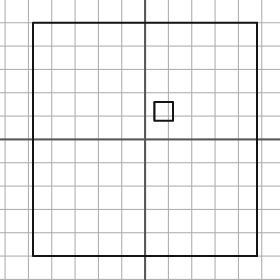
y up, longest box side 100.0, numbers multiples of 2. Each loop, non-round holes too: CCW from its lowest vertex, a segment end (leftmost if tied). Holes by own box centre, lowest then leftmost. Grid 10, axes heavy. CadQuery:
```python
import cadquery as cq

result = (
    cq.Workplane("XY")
    .moveTo(-48.0, -50.0)
    .lineTo(48.0, -50.0)
    .lineTo(48.0, 50.0)
    .lineTo(-48.0, 50.0)
    .close()
    .moveTo(4.0, 8.0)
    .lineTo(12.0, 8.0)
    .lineTo(12.0, 16.0)
    .lineTo(4.0, 16.0)
    .close()
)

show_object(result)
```